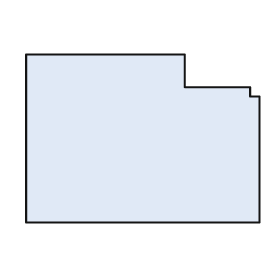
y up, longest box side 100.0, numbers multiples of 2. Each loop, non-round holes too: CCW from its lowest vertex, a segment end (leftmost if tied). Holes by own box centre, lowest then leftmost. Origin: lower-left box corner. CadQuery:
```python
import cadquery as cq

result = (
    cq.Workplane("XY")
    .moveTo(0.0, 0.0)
    .lineTo(100.0, 0.0)
    .lineTo(100.0, 54.0)
    .lineTo(96.0, 54.0)
    .lineTo(96.0, 58.0)
    .lineTo(68.0, 58.0)
    .lineTo(68.0, 72.0)
    .lineTo(0.0, 72.0)
    .close()
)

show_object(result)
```